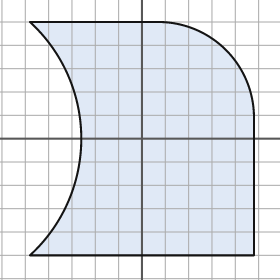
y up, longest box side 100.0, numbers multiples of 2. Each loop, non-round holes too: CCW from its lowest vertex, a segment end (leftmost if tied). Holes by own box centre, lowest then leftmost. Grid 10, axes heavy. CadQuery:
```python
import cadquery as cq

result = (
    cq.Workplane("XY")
    .moveTo(-48.0, -50.0)
    .lineTo(48.0, -50.0)
    .lineTo(48.0, 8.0)
    .threePointArc((36.0, 38.0), (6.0, 50.0))
    .lineTo(-48.0, 50.0)
    .threePointArc((-26.0, 0.0), (-48.0, -50.0))
    .close()
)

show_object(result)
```